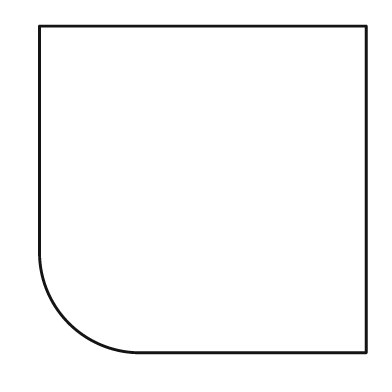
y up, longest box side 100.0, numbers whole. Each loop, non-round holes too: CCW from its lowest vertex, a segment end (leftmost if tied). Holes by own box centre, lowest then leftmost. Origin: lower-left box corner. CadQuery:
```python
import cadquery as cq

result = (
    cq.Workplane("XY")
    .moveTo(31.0, 0.0)
    .lineTo(100.0, 0.0)
    .lineTo(100.0, 100.0)
    .lineTo(0.0, 100.0)
    .lineTo(0.0, 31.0)
    .threePointArc((9.0, 9.0), (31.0, 0.0))
    .close()
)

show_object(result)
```